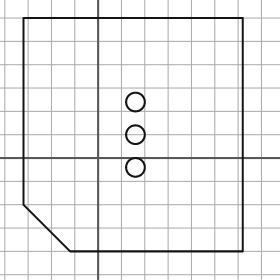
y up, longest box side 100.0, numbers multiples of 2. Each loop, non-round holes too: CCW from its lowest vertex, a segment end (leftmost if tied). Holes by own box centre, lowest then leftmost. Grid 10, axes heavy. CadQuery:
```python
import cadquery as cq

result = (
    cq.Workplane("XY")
    .moveTo(-12.0, -40.0)
    .lineTo(62.0, -40.0)
    .lineTo(62.0, 60.0)
    .lineTo(-32.0, 60.0)
    .lineTo(-32.0, -20.0)
    .close()
    .moveTo(16.0, -4.0)
    .circle(4.0)
    .moveTo(16.0, 10.0)
    .circle(4.0)
    .moveTo(16.0, 24.0)
    .circle(4.0)
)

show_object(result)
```